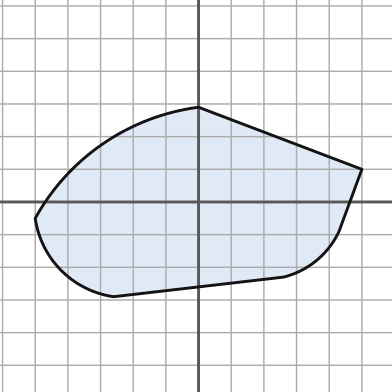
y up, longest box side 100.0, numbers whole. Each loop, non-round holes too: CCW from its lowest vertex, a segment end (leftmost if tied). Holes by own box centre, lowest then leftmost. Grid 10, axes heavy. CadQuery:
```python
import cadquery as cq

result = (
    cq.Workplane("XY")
    .moveTo(-26.0, -29.0)
    .lineTo(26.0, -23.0)
    .threePointArc((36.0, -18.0), (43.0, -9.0))
    .lineTo(50.0, 10.0)
    .lineTo(0.0, 29.0)
    .threePointArc((-29.0, 18.0), (-50.0, -5.0))
    .threePointArc((-42.0, -21.0), (-26.0, -29.0))
    .close()
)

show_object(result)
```